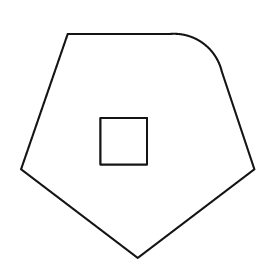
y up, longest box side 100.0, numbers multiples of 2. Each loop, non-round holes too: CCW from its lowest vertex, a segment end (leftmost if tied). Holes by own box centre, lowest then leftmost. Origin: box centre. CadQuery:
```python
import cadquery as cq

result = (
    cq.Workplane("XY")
    .moveTo(0.0, -48.0)
    .lineTo(50.0, -10.0)
    .lineTo(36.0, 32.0)
    .threePointArc((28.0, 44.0), (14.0, 48.0))
    .lineTo(-30.0, 48.0)
    .lineTo(-50.0, -10.0)
    .close()
    .moveTo(-16.0, -8.0)
    .lineTo(4.0, -8.0)
    .lineTo(4.0, 12.0)
    .lineTo(-16.0, 12.0)
    .close()
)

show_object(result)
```